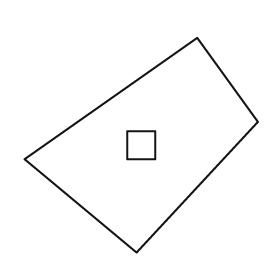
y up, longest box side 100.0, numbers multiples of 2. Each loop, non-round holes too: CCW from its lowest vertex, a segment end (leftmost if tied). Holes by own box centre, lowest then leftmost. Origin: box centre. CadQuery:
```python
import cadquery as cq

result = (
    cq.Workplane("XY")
    .moveTo(-2.0, -46.0)
    .lineTo(50.0, 10.0)
    .lineTo(24.0, 46.0)
    .lineTo(-50.0, -6.0)
    .close()
    .moveTo(-6.0, -6.0)
    .lineTo(6.0, -6.0)
    .lineTo(6.0, 6.0)
    .lineTo(-6.0, 6.0)
    .close()
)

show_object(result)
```